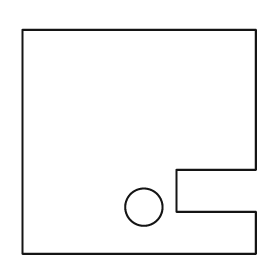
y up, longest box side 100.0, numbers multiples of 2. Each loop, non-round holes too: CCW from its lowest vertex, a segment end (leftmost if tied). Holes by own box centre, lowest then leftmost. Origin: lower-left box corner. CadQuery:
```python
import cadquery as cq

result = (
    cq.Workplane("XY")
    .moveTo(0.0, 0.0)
    .lineTo(100.0, 0.0)
    .lineTo(100.0, 18.0)
    .lineTo(66.0, 18.0)
    .lineTo(66.0, 36.0)
    .lineTo(100.0, 36.0)
    .lineTo(100.0, 96.0)
    .lineTo(0.0, 96.0)
    .close()
    .moveTo(52.0, 20.0)
    .circle(8.0)
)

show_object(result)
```